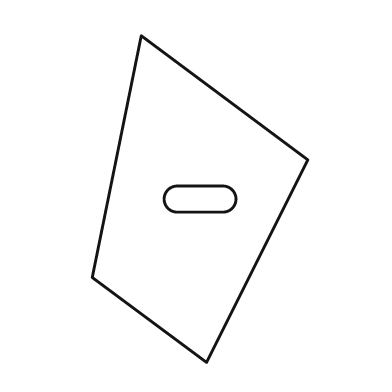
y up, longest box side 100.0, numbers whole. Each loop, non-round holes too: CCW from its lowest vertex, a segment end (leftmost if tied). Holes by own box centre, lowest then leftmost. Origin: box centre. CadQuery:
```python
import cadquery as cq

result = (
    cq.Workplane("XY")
    .moveTo(2.0, -50.0)
    .lineTo(33.0, 12.0)
    .lineTo(-18.0, 50.0)
    .lineTo(-33.0, -24.0)
    .close()
    .moveTo(-7.0, -4.0)
    .lineTo(7.0, -4.0)
    .threePointArc((11.0, 0.0), (7.0, 4.0))
    .lineTo(-7.0, 4.0)
    .threePointArc((-11.0, 0.0), (-7.0, -4.0))
    .close()
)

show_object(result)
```